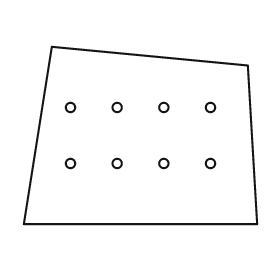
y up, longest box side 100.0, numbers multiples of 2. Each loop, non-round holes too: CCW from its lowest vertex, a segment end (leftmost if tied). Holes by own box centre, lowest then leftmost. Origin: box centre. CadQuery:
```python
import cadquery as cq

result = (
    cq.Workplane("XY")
    .moveTo(-50.0, -38.0)
    .lineTo(50.0, -38.0)
    .lineTo(46.0, 30.0)
    .lineTo(-38.0, 38.0)
    .close()
    .moveTo(-30.0, -12.0)
    .circle(2.0)
    .moveTo(-10.0, -12.0)
    .circle(2.0)
    .moveTo(10.0, -12.0)
    .circle(2.0)
    .moveTo(30.0, -12.0)
    .circle(2.0)
    .moveTo(-30.0, 12.0)
    .circle(2.0)
    .moveTo(-10.0, 12.0)
    .circle(2.0)
    .moveTo(10.0, 12.0)
    .circle(2.0)
    .moveTo(30.0, 12.0)
    .circle(2.0)
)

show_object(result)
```